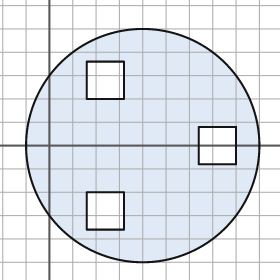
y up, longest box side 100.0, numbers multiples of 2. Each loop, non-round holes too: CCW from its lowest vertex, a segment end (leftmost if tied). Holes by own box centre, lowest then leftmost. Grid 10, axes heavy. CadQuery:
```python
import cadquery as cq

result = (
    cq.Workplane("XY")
    .moveTo(40.0, 0.0)
    .circle(50.0)
    .moveTo(16.0, -36.0)
    .lineTo(32.0, -36.0)
    .lineTo(32.0, -20.0)
    .lineTo(16.0, -20.0)
    .close()
    .moveTo(64.0, -8.0)
    .lineTo(80.0, -8.0)
    .lineTo(80.0, 8.0)
    .lineTo(64.0, 8.0)
    .close()
    .moveTo(16.0, 20.0)
    .lineTo(32.0, 20.0)
    .lineTo(32.0, 36.0)
    .lineTo(16.0, 36.0)
    .close()
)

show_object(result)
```